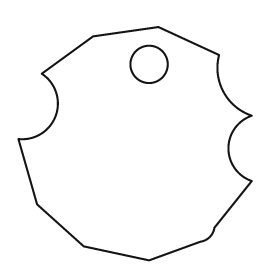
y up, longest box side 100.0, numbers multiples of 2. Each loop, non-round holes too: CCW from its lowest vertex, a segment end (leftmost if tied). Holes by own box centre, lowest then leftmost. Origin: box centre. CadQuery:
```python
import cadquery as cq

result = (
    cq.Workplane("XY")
    .moveTo(6.0, -50.0)
    .lineTo(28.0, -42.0)
    .threePointArc((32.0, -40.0), (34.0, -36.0))
    .lineTo(50.0, -16.0)
    .threePointArc((40.0, -2.0), (50.0, 12.0))
    .threePointArc((38.0, 22.0), (36.0, 38.0))
    .lineTo(10.0, 50.0)
    .lineTo(-18.0, 46.0)
    .lineTo(-40.0, 30.0)
    .threePointArc((-34.0, 12.0), (-50.0, 2.0))
    .lineTo(-42.0, -26.0)
    .lineTo(-22.0, -44.0)
    .close()
    .moveTo(6.0, 34.0)
    .circle(8.0)
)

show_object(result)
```